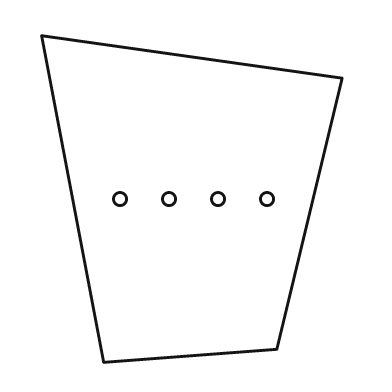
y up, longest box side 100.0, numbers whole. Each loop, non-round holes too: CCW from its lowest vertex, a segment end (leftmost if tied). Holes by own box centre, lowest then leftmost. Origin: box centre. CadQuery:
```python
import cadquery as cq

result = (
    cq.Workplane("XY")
    .moveTo(-27.0, -50.0)
    .lineTo(26.0, -46.0)
    .lineTo(46.0, 37.0)
    .lineTo(-46.0, 50.0)
    .close()
    .moveTo(-22.0, 0.0)
    .circle(2.0)
    .moveTo(-7.0, 0.0)
    .circle(2.0)
    .moveTo(8.0, 0.0)
    .circle(2.0)
    .moveTo(23.0, 0.0)
    .circle(2.0)
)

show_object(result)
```